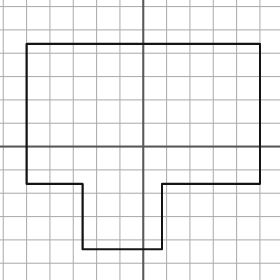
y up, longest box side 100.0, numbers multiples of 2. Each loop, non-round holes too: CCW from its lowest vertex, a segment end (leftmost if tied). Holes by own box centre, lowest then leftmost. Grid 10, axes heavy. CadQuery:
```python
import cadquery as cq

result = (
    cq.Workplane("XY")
    .moveTo(-26.0, -44.0)
    .lineTo(8.0, -44.0)
    .lineTo(8.0, -16.0)
    .lineTo(50.0, -16.0)
    .lineTo(50.0, 44.0)
    .lineTo(-50.0, 44.0)
    .lineTo(-50.0, -16.0)
    .lineTo(-26.0, -16.0)
    .close()
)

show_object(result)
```